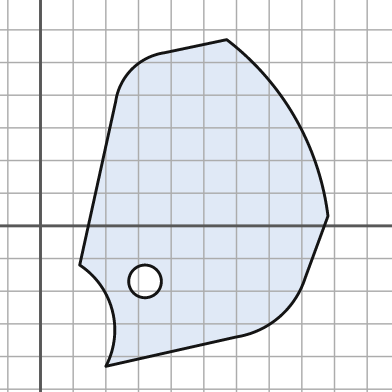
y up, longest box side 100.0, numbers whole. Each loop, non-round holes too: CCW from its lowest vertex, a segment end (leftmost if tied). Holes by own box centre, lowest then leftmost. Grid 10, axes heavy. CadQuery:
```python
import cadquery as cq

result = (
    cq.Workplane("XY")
    .moveTo(20.0, -43.0)
    .lineTo(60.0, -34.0)
    .threePointArc((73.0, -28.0), (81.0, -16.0))
    .lineTo(88.0, 3.0)
    .threePointArc((78.0, 33.0), (57.0, 57.0))
    .lineTo(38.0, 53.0)
    .threePointArc((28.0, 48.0), (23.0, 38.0))
    .lineTo(12.0, -12.0)
    .threePointArc((22.0, -26.0), (20.0, -43.0))
    .close()
    .moveTo(32.0, -17.0)
    .circle(5.0)
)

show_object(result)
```